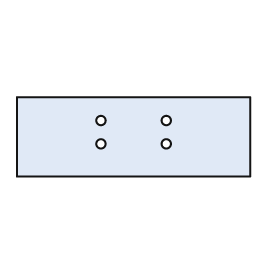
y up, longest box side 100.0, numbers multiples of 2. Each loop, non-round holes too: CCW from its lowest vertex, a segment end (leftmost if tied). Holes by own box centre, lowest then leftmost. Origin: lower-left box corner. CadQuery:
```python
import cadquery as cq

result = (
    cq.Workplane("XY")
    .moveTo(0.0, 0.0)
    .lineTo(100.0, 0.0)
    .lineTo(100.0, 34.0)
    .lineTo(0.0, 34.0)
    .close()
    .moveTo(36.0, 14.0)
    .circle(2.0)
    .moveTo(64.0, 14.0)
    .circle(2.0)
    .moveTo(36.0, 24.0)
    .circle(2.0)
    .moveTo(64.0, 24.0)
    .circle(2.0)
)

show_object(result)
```